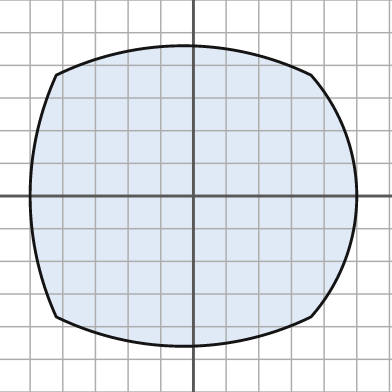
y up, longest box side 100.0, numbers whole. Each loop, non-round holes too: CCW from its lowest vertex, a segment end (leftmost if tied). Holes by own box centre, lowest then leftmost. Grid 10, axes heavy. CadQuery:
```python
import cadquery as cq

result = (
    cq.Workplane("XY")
    .moveTo(-42.0, -37.0)
    .threePointArc((-3.0, -46.0), (36.0, -37.0))
    .threePointArc((50.0, 0.0), (36.0, 37.0))
    .threePointArc((-3.0, 46.0), (-42.0, 37.0))
    .threePointArc((-50.0, 0.0), (-42.0, -37.0))
    .close()
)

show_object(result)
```